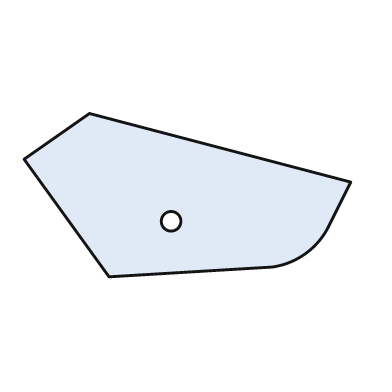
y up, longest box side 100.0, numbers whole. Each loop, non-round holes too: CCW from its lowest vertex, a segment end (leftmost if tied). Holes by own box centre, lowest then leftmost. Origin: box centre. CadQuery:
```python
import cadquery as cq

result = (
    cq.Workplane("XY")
    .moveTo(-24.0, -25.0)
    .lineTo(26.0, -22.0)
    .threePointArc((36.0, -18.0), (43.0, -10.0))
    .lineTo(50.0, 4.0)
    .lineTo(-30.0, 25.0)
    .lineTo(-50.0, 11.0)
    .close()
    .moveTo(-5.0, -8.0)
    .circle(3.0)
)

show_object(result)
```